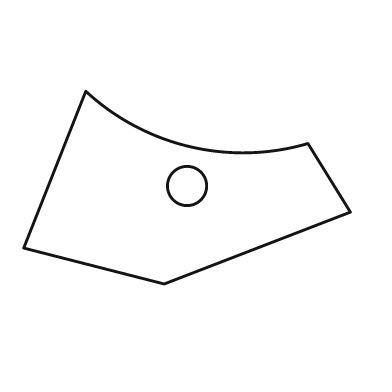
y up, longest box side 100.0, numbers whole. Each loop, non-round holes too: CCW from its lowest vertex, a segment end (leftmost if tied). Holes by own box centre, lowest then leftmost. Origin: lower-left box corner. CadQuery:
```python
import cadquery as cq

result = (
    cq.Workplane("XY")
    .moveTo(43.0, 0.0)
    .lineTo(100.0, 22.0)
    .lineTo(87.0, 43.0)
    .threePointArc((51.0, 42.0), (19.0, 59.0))
    .lineTo(0.0, 11.0)
    .close()
    .moveTo(50.0, 30.0)
    .circle(6.0)
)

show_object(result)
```